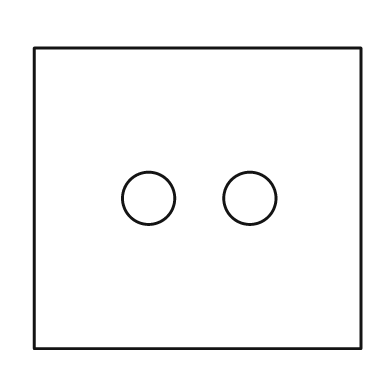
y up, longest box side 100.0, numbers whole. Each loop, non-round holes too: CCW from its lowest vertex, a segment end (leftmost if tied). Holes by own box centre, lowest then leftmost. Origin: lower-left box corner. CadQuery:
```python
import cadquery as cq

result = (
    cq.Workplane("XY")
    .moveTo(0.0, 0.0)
    .lineTo(100.0, 0.0)
    .lineTo(100.0, 92.0)
    .lineTo(0.0, 92.0)
    .close()
    .moveTo(35.0, 46.0)
    .circle(8.0)
    .moveTo(66.0, 46.0)
    .circle(8.0)
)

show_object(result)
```